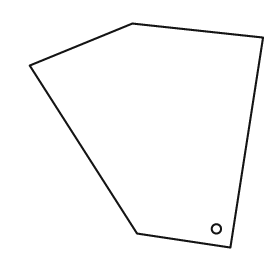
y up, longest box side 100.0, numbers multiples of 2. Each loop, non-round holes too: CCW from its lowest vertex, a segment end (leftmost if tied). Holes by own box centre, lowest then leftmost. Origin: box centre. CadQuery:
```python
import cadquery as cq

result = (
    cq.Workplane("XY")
    .moveTo(36.0, -48.0)
    .lineTo(50.0, 42.0)
    .lineTo(-6.0, 48.0)
    .lineTo(-50.0, 30.0)
    .lineTo(-4.0, -42.0)
    .close()
    .moveTo(30.0, -40.0)
    .circle(2.0)
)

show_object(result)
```